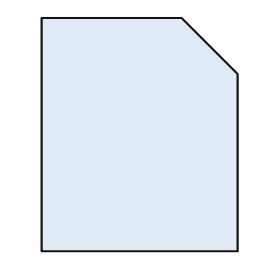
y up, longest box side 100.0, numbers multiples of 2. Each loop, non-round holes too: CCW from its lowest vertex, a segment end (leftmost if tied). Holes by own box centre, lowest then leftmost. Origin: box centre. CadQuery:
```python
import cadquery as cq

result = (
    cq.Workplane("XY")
    .moveTo(-42.0, -50.0)
    .lineTo(42.0, -50.0)
    .lineTo(42.0, 26.0)
    .lineTo(18.0, 50.0)
    .lineTo(-42.0, 50.0)
    .close()
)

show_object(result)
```